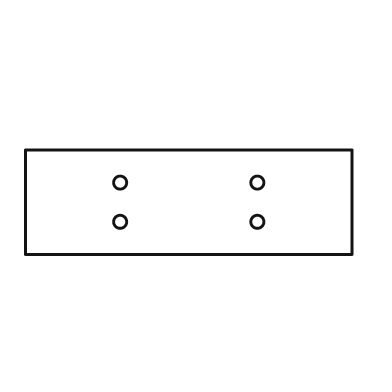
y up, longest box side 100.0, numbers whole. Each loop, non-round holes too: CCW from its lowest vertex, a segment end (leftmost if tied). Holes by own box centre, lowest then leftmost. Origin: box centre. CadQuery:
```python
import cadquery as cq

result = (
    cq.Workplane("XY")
    .moveTo(-50.0, -16.0)
    .lineTo(50.0, -16.0)
    .lineTo(50.0, 16.0)
    .lineTo(-50.0, 16.0)
    .close()
    .moveTo(-21.0, -6.0)
    .circle(2.0)
    .moveTo(21.0, -6.0)
    .circle(2.0)
    .moveTo(-21.0, 6.0)
    .circle(2.0)
    .moveTo(21.0, 6.0)
    .circle(2.0)
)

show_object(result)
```